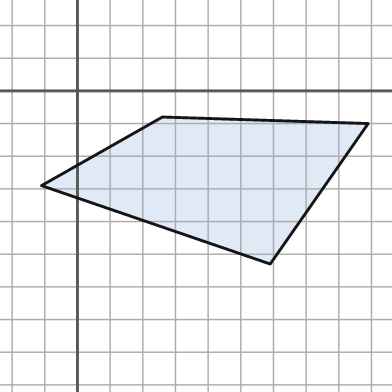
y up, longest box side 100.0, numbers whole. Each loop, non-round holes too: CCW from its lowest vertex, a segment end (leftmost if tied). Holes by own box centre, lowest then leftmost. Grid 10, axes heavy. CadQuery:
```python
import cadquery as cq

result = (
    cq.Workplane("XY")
    .moveTo(59.0, -53.0)
    .lineTo(89.0, -10.0)
    .lineTo(26.0, -8.0)
    .lineTo(-11.0, -29.0)
    .close()
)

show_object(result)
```